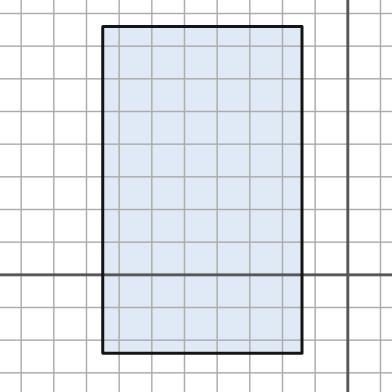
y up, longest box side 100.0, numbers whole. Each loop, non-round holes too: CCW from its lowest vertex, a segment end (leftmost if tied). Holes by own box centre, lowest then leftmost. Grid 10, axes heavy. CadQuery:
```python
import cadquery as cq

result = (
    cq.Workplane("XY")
    .moveTo(-75.0, -24.0)
    .lineTo(-14.0, -24.0)
    .lineTo(-14.0, 76.0)
    .lineTo(-75.0, 76.0)
    .close()
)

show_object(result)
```